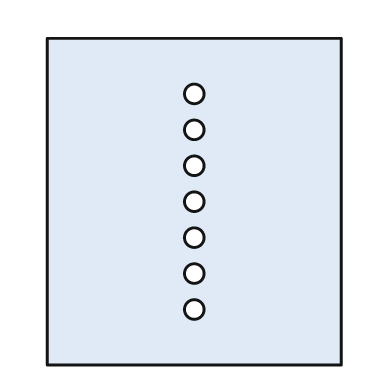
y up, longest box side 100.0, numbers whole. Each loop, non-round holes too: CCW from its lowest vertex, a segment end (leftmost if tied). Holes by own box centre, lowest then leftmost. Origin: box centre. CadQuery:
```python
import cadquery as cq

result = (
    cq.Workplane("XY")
    .moveTo(-45.0, -50.0)
    .lineTo(45.0, -50.0)
    .lineTo(45.0, 50.0)
    .lineTo(-45.0, 50.0)
    .close()
    .moveTo(0.0, -33.0)
    .circle(3.0)
    .moveTo(0.0, -22.0)
    .circle(3.0)
    .moveTo(0.0, -11.0)
    .circle(3.0)
    .moveTo(0.0, 0.0)
    .circle(3.0)
    .moveTo(0.0, 11.0)
    .circle(3.0)
    .moveTo(0.0, 22.0)
    .circle(3.0)
    .moveTo(0.0, 33.0)
    .circle(3.0)
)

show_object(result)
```